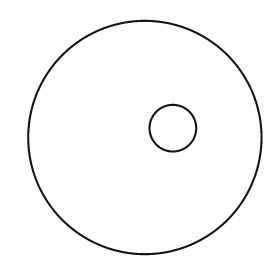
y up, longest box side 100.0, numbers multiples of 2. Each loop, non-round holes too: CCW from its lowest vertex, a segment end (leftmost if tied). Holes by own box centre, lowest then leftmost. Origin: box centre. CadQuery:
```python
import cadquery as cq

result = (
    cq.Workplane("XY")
    .moveTo(0.0, 0.0)
    .circle(50.0)
    .moveTo(12.0, 4.0)
    .circle(10.0)
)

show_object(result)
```